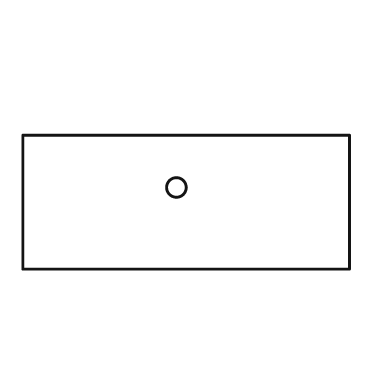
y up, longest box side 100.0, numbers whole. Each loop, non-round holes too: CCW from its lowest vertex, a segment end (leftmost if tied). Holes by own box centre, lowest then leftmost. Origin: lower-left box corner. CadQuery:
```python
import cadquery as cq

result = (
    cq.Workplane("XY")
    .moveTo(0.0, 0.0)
    .lineTo(100.0, 0.0)
    .lineTo(100.0, 41.0)
    .lineTo(0.0, 41.0)
    .close()
    .moveTo(47.0, 25.0)
    .circle(3.0)
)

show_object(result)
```